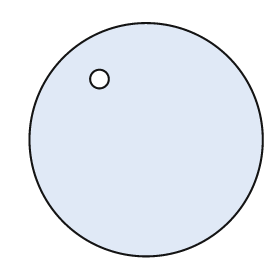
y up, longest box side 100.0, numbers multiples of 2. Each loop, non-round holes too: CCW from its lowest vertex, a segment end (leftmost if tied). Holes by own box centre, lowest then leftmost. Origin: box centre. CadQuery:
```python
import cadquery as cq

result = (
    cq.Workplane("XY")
    .moveTo(0.0, 0.0)
    .circle(50.0)
    .moveTo(-20.0, 26.0)
    .circle(4.0)
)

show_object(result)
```